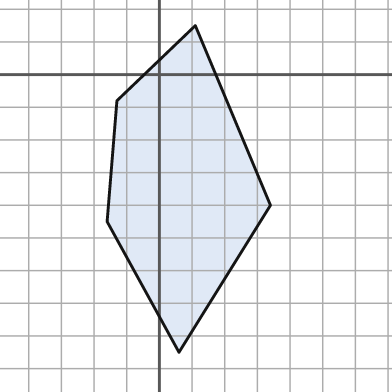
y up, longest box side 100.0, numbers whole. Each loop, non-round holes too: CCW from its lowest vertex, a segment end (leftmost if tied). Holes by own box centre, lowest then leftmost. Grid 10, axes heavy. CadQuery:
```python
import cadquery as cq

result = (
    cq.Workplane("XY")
    .moveTo(6.0, -85.0)
    .lineTo(34.0, -40.0)
    .lineTo(11.0, 15.0)
    .lineTo(-13.0, -8.0)
    .lineTo(-16.0, -45.0)
    .close()
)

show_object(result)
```